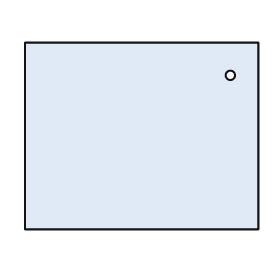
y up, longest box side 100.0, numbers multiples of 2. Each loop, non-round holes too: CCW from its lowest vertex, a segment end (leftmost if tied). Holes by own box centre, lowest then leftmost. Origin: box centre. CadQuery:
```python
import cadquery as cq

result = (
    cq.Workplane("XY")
    .moveTo(-50.0, -40.0)
    .lineTo(50.0, -40.0)
    .lineTo(50.0, 40.0)
    .lineTo(-50.0, 40.0)
    .close()
    .moveTo(38.0, 26.0)
    .circle(2.0)
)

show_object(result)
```